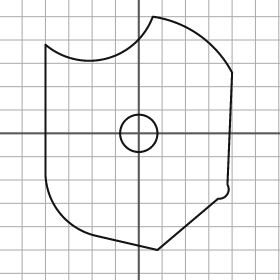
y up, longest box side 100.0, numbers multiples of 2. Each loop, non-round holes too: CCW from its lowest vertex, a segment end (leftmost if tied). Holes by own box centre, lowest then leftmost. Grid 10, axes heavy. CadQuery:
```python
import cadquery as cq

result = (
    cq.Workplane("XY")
    .moveTo(8.0, -50.0)
    .lineTo(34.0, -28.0)
    .threePointArc((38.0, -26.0), (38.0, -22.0))
    .lineTo(40.0, 26.0)
    .threePointArc((26.0, 42.0), (6.0, 50.0))
    .threePointArc((-14.0, 32.0), (-40.0, 38.0))
    .lineTo(-40.0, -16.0)
    .threePointArc((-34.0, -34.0), (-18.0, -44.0))
    .close()
    .moveTo(0.0, 0.0)
    .circle(8.0)
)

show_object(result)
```